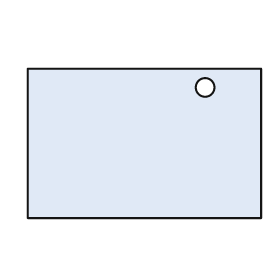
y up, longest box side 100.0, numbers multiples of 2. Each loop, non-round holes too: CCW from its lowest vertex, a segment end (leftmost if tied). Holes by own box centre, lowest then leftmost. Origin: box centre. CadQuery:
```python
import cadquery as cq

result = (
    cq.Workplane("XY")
    .moveTo(-50.0, -32.0)
    .lineTo(50.0, -32.0)
    .lineTo(50.0, 32.0)
    .lineTo(-50.0, 32.0)
    .close()
    .moveTo(26.0, 24.0)
    .circle(4.0)
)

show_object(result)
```